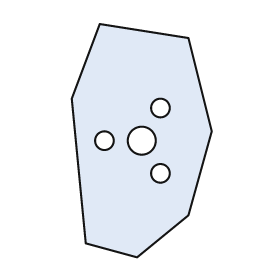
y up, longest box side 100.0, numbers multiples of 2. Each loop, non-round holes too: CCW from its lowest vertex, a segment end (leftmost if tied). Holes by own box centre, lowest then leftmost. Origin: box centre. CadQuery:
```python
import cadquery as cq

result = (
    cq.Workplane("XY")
    .moveTo(-2.0, -50.0)
    .lineTo(20.0, -32.0)
    .lineTo(30.0, 4.0)
    .lineTo(20.0, 44.0)
    .lineTo(-18.0, 50.0)
    .lineTo(-30.0, 18.0)
    .lineTo(-24.0, -44.0)
    .close()
    .moveTo(8.0, -14.0)
    .circle(4.0)
    .moveTo(-16.0, 0.0)
    .circle(4.0)
    .moveTo(0.0, 0.0)
    .circle(6.0)
    .moveTo(8.0, 14.0)
    .circle(4.0)
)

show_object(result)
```